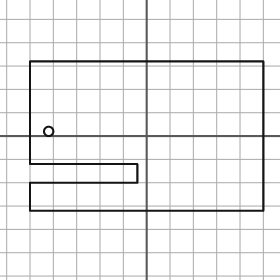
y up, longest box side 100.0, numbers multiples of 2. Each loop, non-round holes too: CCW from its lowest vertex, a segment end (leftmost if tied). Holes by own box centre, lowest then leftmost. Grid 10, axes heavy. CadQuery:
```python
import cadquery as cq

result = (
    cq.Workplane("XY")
    .moveTo(-50.0, -32.0)
    .lineTo(50.0, -32.0)
    .lineTo(50.0, 32.0)
    .lineTo(-50.0, 32.0)
    .lineTo(-50.0, -12.0)
    .lineTo(-4.0, -12.0)
    .lineTo(-4.0, -20.0)
    .lineTo(-50.0, -20.0)
    .close()
    .moveTo(-42.0, 2.0)
    .circle(2.0)
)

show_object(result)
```